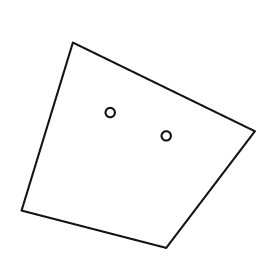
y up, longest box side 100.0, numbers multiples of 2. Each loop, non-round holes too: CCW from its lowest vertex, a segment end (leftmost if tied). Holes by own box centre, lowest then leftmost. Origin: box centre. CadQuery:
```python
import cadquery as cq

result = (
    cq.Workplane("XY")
    .moveTo(12.0, -44.0)
    .lineTo(50.0, 6.0)
    .lineTo(-28.0, 44.0)
    .lineTo(-50.0, -28.0)
    .close()
    .moveTo(12.0, 4.0)
    .circle(2.0)
    .moveTo(-12.0, 14.0)
    .circle(2.0)
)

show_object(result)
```